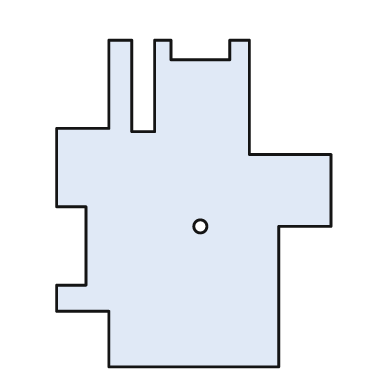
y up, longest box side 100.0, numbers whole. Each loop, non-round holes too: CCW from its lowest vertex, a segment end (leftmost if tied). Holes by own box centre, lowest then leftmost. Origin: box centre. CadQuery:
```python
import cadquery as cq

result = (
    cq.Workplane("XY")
    .moveTo(-26.0, -50.0)
    .lineTo(26.0, -50.0)
    .lineTo(26.0, -7.0)
    .lineTo(42.0, -7.0)
    .lineTo(42.0, 15.0)
    .lineTo(17.0, 15.0)
    .lineTo(17.0, 50.0)
    .lineTo(11.0, 50.0)
    .lineTo(11.0, 44.0)
    .lineTo(-7.0, 44.0)
    .lineTo(-7.0, 50.0)
    .lineTo(-12.0, 50.0)
    .lineTo(-12.0, 22.0)
    .lineTo(-19.0, 22.0)
    .lineTo(-19.0, 50.0)
    .lineTo(-26.0, 50.0)
    .lineTo(-26.0, 23.0)
    .lineTo(-42.0, 23.0)
    .lineTo(-42.0, -1.0)
    .lineTo(-33.0, -1.0)
    .lineTo(-33.0, -25.0)
    .lineTo(-42.0, -25.0)
    .lineTo(-42.0, -33.0)
    .lineTo(-26.0, -33.0)
    .close()
    .moveTo(2.0, -7.0)
    .circle(2.0)
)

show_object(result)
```